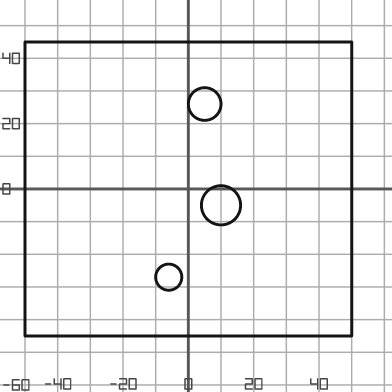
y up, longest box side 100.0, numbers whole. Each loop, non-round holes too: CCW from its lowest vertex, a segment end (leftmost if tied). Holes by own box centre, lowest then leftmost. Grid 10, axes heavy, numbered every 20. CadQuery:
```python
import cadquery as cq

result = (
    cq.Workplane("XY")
    .moveTo(-50.0, -45.0)
    .lineTo(50.0, -45.0)
    .lineTo(50.0, 45.0)
    .lineTo(-50.0, 45.0)
    .close()
    .moveTo(-6.0, -27.0)
    .circle(4.0)
    .moveTo(10.0, -5.0)
    .circle(6.0)
    .moveTo(5.0, 26.0)
    .circle(5.0)
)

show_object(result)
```